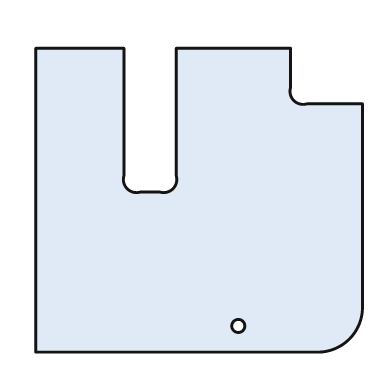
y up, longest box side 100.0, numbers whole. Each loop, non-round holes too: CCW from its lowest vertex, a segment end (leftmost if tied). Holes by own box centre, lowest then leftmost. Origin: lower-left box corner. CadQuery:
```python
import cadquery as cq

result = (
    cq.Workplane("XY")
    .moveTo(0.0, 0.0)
    .lineTo(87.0, 0.0)
    .threePointArc((96.0, 4.0), (100.0, 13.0))
    .lineTo(100.0, 76.0)
    .lineTo(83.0, 76.0)
    .threePointArc((79.0, 77.0), (78.0, 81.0))
    .lineTo(78.0, 93.0)
    .lineTo(43.0, 93.0)
    .lineTo(43.0, 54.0)
    .threePointArc((42.0, 50.0), (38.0, 49.0))
    .lineTo(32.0, 49.0)
    .threePointArc((28.0, 50.0), (27.0, 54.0))
    .lineTo(27.0, 93.0)
    .lineTo(0.0, 93.0)
    .close()
    .moveTo(62.0, 8.0)
    .circle(2.0)
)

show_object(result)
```